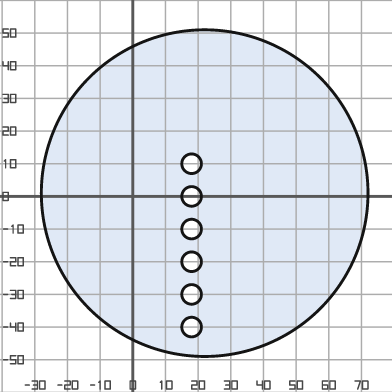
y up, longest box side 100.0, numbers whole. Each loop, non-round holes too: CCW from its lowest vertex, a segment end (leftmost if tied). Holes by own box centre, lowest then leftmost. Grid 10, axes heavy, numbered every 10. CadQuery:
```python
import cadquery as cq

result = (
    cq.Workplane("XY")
    .moveTo(22.0, 1.0)
    .circle(50.0)
    .moveTo(18.0, -40.0)
    .circle(3.0)
    .moveTo(18.0, -30.0)
    .circle(3.0)
    .moveTo(18.0, -20.0)
    .circle(3.0)
    .moveTo(18.0, -10.0)
    .circle(3.0)
    .moveTo(18.0, 0.0)
    .circle(3.0)
    .moveTo(18.0, 10.0)
    .circle(3.0)
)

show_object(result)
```